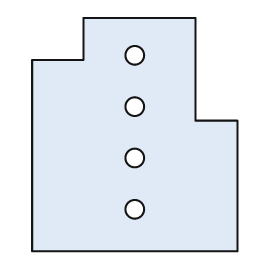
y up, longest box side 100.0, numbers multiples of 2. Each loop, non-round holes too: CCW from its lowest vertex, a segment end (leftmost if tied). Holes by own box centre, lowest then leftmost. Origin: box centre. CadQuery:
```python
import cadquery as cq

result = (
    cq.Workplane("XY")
    .moveTo(-44.0, -50.0)
    .lineTo(44.0, -50.0)
    .lineTo(44.0, 6.0)
    .lineTo(26.0, 6.0)
    .lineTo(26.0, 50.0)
    .lineTo(-22.0, 50.0)
    .lineTo(-22.0, 32.0)
    .lineTo(-44.0, 32.0)
    .close()
    .moveTo(0.0, -32.0)
    .circle(4.0)
    .moveTo(0.0, -10.0)
    .circle(4.0)
    .moveTo(0.0, 12.0)
    .circle(4.0)
    .moveTo(0.0, 34.0)
    .circle(4.0)
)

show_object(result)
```